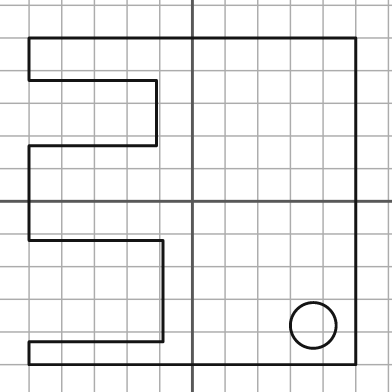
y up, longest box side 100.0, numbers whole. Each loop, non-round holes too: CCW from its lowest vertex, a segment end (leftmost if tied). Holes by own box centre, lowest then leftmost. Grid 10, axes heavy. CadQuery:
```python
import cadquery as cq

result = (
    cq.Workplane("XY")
    .moveTo(-50.0, -50.0)
    .lineTo(50.0, -50.0)
    .lineTo(50.0, 50.0)
    .lineTo(-50.0, 50.0)
    .lineTo(-50.0, 37.0)
    .lineTo(-11.0, 37.0)
    .lineTo(-11.0, 17.0)
    .lineTo(-50.0, 17.0)
    .lineTo(-50.0, -12.0)
    .lineTo(-9.0, -12.0)
    .lineTo(-9.0, -43.0)
    .lineTo(-50.0, -43.0)
    .close()
    .moveTo(37.0, -38.0)
    .circle(7.0)
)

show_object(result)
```